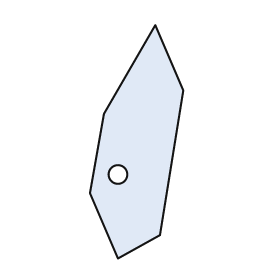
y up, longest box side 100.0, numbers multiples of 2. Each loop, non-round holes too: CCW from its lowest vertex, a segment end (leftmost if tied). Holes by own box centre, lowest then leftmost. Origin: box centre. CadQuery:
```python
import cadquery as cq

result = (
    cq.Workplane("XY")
    .moveTo(-8.0, -50.0)
    .lineTo(10.0, -40.0)
    .lineTo(20.0, 22.0)
    .lineTo(8.0, 50.0)
    .lineTo(-14.0, 12.0)
    .lineTo(-20.0, -22.0)
    .close()
    .moveTo(-8.0, -14.0)
    .circle(4.0)
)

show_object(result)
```